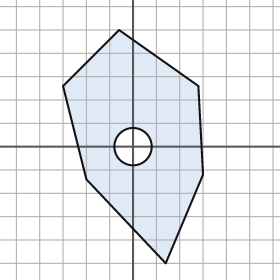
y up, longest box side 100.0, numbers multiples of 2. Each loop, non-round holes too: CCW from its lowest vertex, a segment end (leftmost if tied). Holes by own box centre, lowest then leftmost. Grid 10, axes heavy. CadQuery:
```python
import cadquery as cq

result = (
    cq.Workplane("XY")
    .moveTo(14.0, -50.0)
    .lineTo(30.0, -12.0)
    .lineTo(28.0, 26.0)
    .lineTo(-6.0, 50.0)
    .lineTo(-30.0, 26.0)
    .lineTo(-20.0, -14.0)
    .close()
    .moveTo(0.0, 0.0)
    .circle(8.0)
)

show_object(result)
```